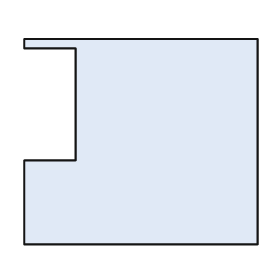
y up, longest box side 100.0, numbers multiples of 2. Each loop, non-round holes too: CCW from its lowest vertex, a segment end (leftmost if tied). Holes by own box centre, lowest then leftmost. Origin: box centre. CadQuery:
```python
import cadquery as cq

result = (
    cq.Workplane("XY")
    .moveTo(-50.0, -44.0)
    .lineTo(50.0, -44.0)
    .lineTo(50.0, 44.0)
    .lineTo(-50.0, 44.0)
    .lineTo(-50.0, 40.0)
    .lineTo(-28.0, 40.0)
    .lineTo(-28.0, -8.0)
    .lineTo(-50.0, -8.0)
    .close()
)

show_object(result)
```